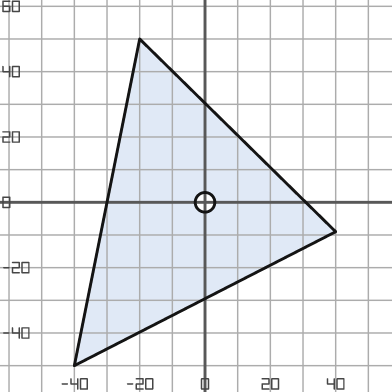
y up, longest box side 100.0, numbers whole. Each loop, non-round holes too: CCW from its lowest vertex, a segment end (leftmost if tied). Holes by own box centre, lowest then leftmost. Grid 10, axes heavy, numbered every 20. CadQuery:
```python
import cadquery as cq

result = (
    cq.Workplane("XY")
    .moveTo(-40.0, -50.0)
    .lineTo(40.0, -9.0)
    .lineTo(-20.0, 50.0)
    .close()
    .moveTo(0.0, 0.0)
    .circle(3.0)
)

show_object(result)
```